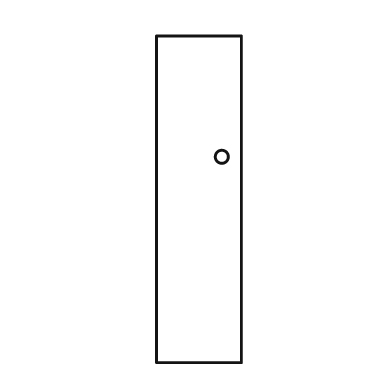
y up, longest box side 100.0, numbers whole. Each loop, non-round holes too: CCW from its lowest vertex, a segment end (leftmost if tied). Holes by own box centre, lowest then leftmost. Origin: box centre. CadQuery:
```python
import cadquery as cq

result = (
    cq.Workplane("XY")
    .moveTo(-13.0, -50.0)
    .lineTo(13.0, -50.0)
    .lineTo(13.0, 50.0)
    .lineTo(-13.0, 50.0)
    .close()
    .moveTo(7.0, 13.0)
    .circle(2.0)
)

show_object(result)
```